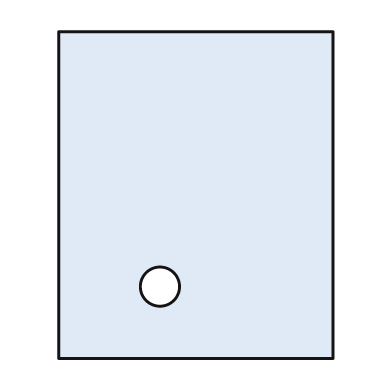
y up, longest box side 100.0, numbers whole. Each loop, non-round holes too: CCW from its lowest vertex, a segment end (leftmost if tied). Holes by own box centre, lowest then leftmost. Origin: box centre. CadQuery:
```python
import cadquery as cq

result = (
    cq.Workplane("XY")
    .moveTo(-42.0, -50.0)
    .lineTo(42.0, -50.0)
    .lineTo(42.0, 50.0)
    .lineTo(-42.0, 50.0)
    .close()
    .moveTo(-11.0, -28.0)
    .circle(6.0)
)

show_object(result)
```